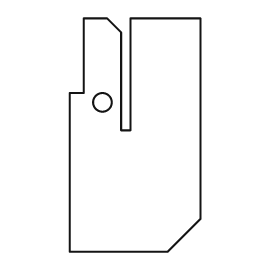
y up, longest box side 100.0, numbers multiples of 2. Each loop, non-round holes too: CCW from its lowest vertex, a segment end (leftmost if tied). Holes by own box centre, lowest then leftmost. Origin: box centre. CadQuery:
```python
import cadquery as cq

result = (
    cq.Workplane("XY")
    .moveTo(-28.0, -50.0)
    .lineTo(14.0, -50.0)
    .lineTo(28.0, -36.0)
    .lineTo(28.0, 50.0)
    .lineTo(-2.0, 50.0)
    .lineTo(-2.0, 2.0)
    .lineTo(-6.0, 2.0)
    .lineTo(-6.0, 44.0)
    .lineTo(-12.0, 50.0)
    .lineTo(-22.0, 50.0)
    .lineTo(-22.0, 18.0)
    .lineTo(-28.0, 18.0)
    .close()
    .moveTo(-14.0, 14.0)
    .circle(4.0)
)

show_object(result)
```